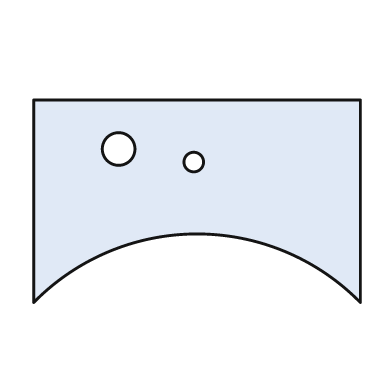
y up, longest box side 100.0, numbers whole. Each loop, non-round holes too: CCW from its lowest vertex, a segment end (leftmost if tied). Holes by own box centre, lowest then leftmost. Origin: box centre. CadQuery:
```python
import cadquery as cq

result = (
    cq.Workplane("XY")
    .moveTo(-50.0, -31.0)
    .threePointArc((0.0, -10.0), (50.0, -31.0))
    .lineTo(50.0, 31.0)
    .lineTo(-50.0, 31.0)
    .close()
    .moveTo(-1.0, 12.0)
    .circle(3.0)
    .moveTo(-24.0, 16.0)
    .circle(5.0)
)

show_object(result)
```